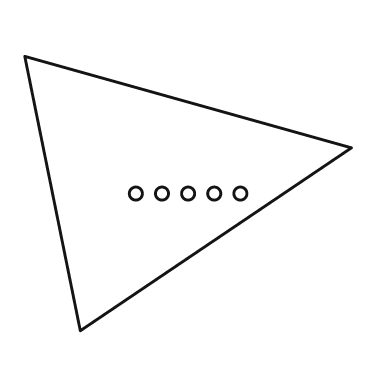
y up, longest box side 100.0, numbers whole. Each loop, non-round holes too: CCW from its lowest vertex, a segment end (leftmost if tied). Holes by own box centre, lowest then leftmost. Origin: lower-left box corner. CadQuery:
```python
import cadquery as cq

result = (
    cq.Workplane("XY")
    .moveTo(17.0, 0.0)
    .lineTo(100.0, 56.0)
    .lineTo(0.0, 84.0)
    .close()
    .moveTo(34.0, 42.0)
    .circle(2.0)
    .moveTo(42.0, 42.0)
    .circle(2.0)
    .moveTo(50.0, 42.0)
    .circle(2.0)
    .moveTo(58.0, 42.0)
    .circle(2.0)
    .moveTo(66.0, 42.0)
    .circle(2.0)
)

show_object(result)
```